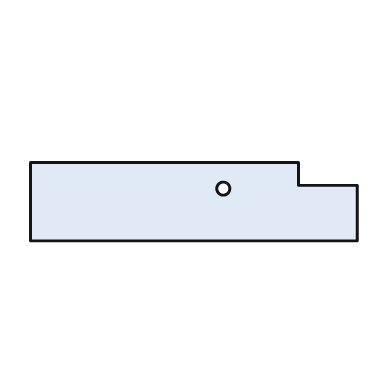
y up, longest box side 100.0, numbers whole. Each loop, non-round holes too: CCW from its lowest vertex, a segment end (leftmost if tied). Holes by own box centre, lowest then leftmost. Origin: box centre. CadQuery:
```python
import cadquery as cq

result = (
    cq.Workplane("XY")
    .moveTo(-50.0, -12.0)
    .lineTo(50.0, -12.0)
    .lineTo(50.0, 5.0)
    .lineTo(32.0, 5.0)
    .lineTo(32.0, 12.0)
    .lineTo(-50.0, 12.0)
    .close()
    .moveTo(9.0, 4.0)
    .circle(2.0)
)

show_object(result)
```